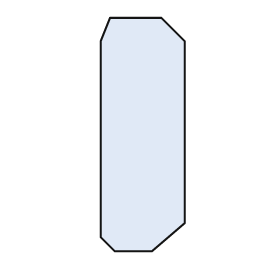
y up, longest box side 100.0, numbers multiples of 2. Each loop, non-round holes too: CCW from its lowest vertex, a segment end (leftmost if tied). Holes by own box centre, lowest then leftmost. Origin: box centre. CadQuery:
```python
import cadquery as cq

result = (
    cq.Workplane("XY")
    .moveTo(-12.0, -50.0)
    .lineTo(4.0, -50.0)
    .lineTo(18.0, -38.0)
    .lineTo(18.0, 40.0)
    .lineTo(8.0, 50.0)
    .lineTo(-14.0, 50.0)
    .lineTo(-18.0, 40.0)
    .lineTo(-18.0, -44.0)
    .close()
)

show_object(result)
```